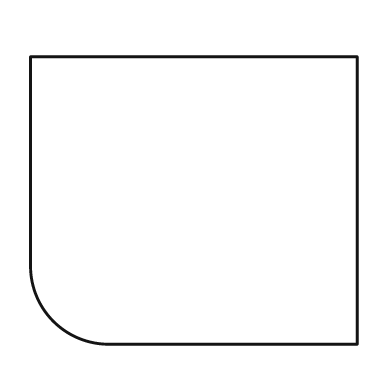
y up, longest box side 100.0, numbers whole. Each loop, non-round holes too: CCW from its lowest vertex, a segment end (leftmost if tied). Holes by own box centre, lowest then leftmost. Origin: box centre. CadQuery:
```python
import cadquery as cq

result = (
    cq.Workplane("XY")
    .moveTo(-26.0, -44.0)
    .lineTo(50.0, -44.0)
    .lineTo(50.0, 44.0)
    .lineTo(-50.0, 44.0)
    .lineTo(-50.0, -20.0)
    .threePointArc((-43.0, -37.0), (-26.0, -44.0))
    .close()
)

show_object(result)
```